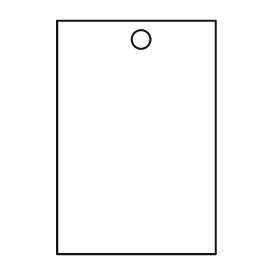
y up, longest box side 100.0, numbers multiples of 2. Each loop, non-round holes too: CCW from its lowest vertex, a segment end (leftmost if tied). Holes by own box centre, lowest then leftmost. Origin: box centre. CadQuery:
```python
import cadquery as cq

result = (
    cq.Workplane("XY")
    .moveTo(-34.0, -50.0)
    .lineTo(34.0, -50.0)
    .lineTo(34.0, 50.0)
    .lineTo(-34.0, 50.0)
    .close()
    .moveTo(2.0, 42.0)
    .circle(4.0)
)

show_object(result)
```